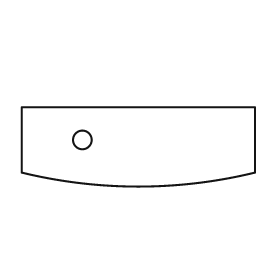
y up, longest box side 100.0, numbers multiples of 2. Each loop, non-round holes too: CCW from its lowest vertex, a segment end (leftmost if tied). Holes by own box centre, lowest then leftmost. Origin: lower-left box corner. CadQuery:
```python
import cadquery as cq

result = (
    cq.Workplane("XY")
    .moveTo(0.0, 6.0)
    .threePointArc((50.0, 0.0), (100.0, 6.0))
    .lineTo(100.0, 34.0)
    .lineTo(0.0, 34.0)
    .close()
    .moveTo(26.0, 20.0)
    .circle(4.0)
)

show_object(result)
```